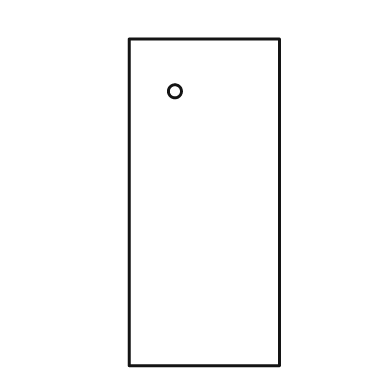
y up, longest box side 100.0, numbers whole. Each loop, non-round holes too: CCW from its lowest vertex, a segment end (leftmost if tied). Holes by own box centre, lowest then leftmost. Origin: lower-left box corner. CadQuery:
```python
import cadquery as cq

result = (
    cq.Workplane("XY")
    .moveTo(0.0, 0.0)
    .lineTo(46.0, 0.0)
    .lineTo(46.0, 100.0)
    .lineTo(0.0, 100.0)
    .close()
    .moveTo(14.0, 84.0)
    .circle(2.0)
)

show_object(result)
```